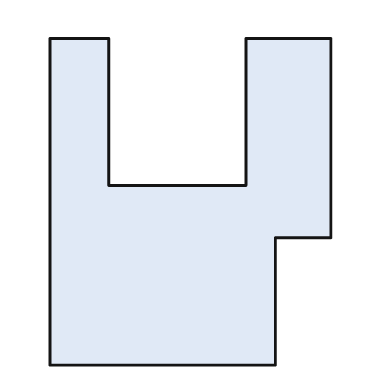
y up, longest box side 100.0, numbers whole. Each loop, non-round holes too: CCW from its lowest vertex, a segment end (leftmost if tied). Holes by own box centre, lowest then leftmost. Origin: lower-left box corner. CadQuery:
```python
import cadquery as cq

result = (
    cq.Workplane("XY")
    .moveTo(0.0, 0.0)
    .lineTo(69.0, 0.0)
    .lineTo(69.0, 39.0)
    .lineTo(86.0, 39.0)
    .lineTo(86.0, 100.0)
    .lineTo(60.0, 100.0)
    .lineTo(60.0, 55.0)
    .lineTo(18.0, 55.0)
    .lineTo(18.0, 100.0)
    .lineTo(0.0, 100.0)
    .close()
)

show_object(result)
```